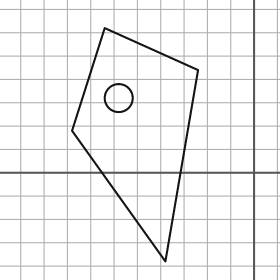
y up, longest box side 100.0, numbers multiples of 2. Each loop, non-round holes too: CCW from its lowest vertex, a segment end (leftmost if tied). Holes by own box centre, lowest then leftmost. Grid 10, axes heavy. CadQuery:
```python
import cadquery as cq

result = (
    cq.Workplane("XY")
    .moveTo(-38.0, -38.0)
    .lineTo(-24.0, 44.0)
    .lineTo(-64.0, 62.0)
    .lineTo(-78.0, 18.0)
    .close()
    .moveTo(-58.0, 32.0)
    .circle(6.0)
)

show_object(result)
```